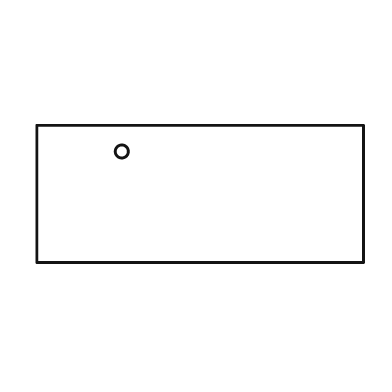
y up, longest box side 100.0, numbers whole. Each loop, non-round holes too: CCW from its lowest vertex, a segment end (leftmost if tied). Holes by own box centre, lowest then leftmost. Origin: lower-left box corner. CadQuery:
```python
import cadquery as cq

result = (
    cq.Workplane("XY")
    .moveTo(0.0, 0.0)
    .lineTo(100.0, 0.0)
    .lineTo(100.0, 42.0)
    .lineTo(0.0, 42.0)
    .close()
    .moveTo(26.0, 34.0)
    .circle(2.0)
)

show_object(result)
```